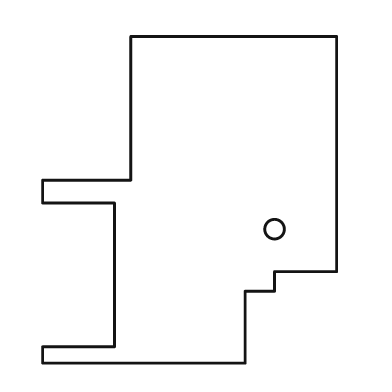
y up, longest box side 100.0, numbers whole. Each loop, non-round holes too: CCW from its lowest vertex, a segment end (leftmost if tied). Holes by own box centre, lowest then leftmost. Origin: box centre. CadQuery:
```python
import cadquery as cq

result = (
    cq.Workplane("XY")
    .moveTo(-45.0, -50.0)
    .lineTo(17.0, -50.0)
    .lineTo(17.0, -28.0)
    .lineTo(26.0, -28.0)
    .lineTo(26.0, -22.0)
    .lineTo(45.0, -22.0)
    .lineTo(45.0, 50.0)
    .lineTo(-18.0, 50.0)
    .lineTo(-18.0, 6.0)
    .lineTo(-45.0, 6.0)
    .lineTo(-45.0, -1.0)
    .lineTo(-23.0, -1.0)
    .lineTo(-23.0, -45.0)
    .lineTo(-45.0, -45.0)
    .close()
    .moveTo(26.0, -9.0)
    .circle(3.0)
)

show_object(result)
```